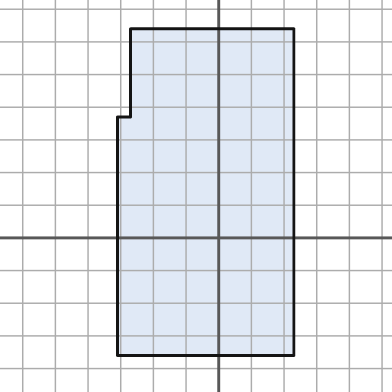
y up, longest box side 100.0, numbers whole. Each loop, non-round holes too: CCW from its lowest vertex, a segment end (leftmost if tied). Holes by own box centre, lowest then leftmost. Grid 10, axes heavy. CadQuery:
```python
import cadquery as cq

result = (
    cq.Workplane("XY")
    .moveTo(-31.0, -36.0)
    .lineTo(23.0, -36.0)
    .lineTo(23.0, 64.0)
    .lineTo(-27.0, 64.0)
    .lineTo(-27.0, 37.0)
    .lineTo(-31.0, 37.0)
    .close()
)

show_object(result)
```